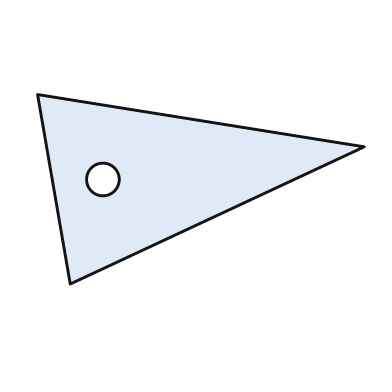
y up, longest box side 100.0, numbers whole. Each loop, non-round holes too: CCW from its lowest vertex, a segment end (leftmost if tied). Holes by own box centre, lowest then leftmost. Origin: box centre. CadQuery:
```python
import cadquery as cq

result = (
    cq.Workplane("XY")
    .moveTo(-40.0, -29.0)
    .lineTo(50.0, 13.0)
    .lineTo(-50.0, 29.0)
    .close()
    .moveTo(-30.0, 3.0)
    .circle(5.0)
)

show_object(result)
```